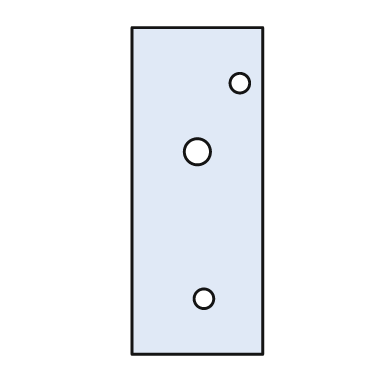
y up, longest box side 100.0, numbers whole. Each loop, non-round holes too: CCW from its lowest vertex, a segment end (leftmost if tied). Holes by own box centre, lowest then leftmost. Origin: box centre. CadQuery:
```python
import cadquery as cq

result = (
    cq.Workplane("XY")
    .moveTo(-20.0, -50.0)
    .lineTo(20.0, -50.0)
    .lineTo(20.0, 50.0)
    .lineTo(-20.0, 50.0)
    .close()
    .moveTo(2.0, -33.0)
    .circle(3.0)
    .moveTo(0.0, 12.0)
    .circle(4.0)
    .moveTo(13.0, 33.0)
    .circle(3.0)
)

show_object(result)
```